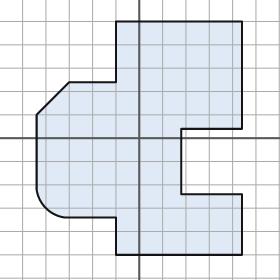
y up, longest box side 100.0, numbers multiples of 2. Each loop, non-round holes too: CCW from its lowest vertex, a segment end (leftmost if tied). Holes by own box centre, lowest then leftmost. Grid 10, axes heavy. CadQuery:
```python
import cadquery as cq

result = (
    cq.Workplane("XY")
    .moveTo(-10.0, -50.0)
    .lineTo(44.0, -50.0)
    .lineTo(44.0, -24.0)
    .lineTo(18.0, -24.0)
    .lineTo(18.0, 4.0)
    .lineTo(44.0, 4.0)
    .lineTo(44.0, 50.0)
    .lineTo(-10.0, 50.0)
    .lineTo(-10.0, 24.0)
    .lineTo(-30.0, 24.0)
    .lineTo(-44.0, 10.0)
    .lineTo(-44.0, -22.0)
    .threePointArc((-40.0, -30.0), (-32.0, -34.0))
    .lineTo(-10.0, -34.0)
    .close()
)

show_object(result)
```